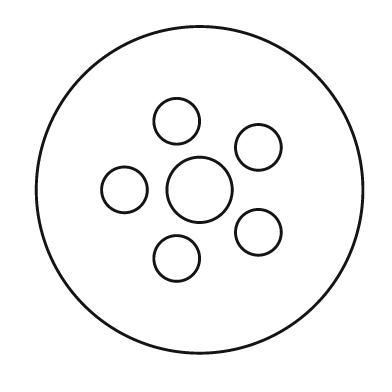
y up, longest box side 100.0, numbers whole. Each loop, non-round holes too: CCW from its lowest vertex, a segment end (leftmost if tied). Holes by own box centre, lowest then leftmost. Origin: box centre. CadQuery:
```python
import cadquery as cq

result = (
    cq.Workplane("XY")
    .moveTo(0.0, 0.0)
    .circle(50.0)
    .moveTo(-7.0, -21.0)
    .circle(7.0)
    .moveTo(18.0, -13.0)
    .circle(7.0)
    .moveTo(-23.0, 0.0)
    .circle(7.0)
    .moveTo(0.0, 0.0)
    .circle(10.0)
    .moveTo(18.0, 13.0)
    .circle(7.0)
    .moveTo(-7.0, 21.0)
    .circle(7.0)
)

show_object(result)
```